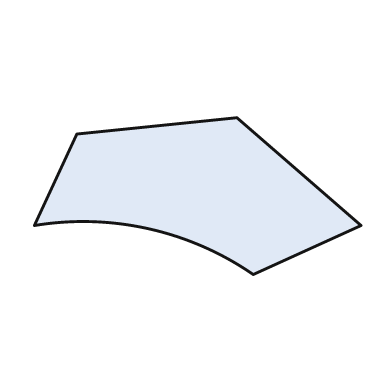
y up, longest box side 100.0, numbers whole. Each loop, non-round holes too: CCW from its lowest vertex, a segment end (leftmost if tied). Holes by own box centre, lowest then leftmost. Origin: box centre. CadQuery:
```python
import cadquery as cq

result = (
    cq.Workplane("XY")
    .moveTo(17.0, -24.0)
    .lineTo(50.0, -9.0)
    .lineTo(12.0, 24.0)
    .lineTo(-37.0, 19.0)
    .lineTo(-50.0, -9.0)
    .threePointArc((-15.0, -10.0), (17.0, -24.0))
    .close()
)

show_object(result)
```